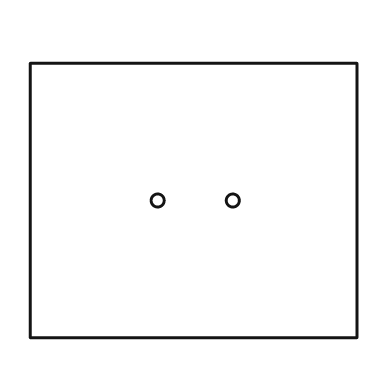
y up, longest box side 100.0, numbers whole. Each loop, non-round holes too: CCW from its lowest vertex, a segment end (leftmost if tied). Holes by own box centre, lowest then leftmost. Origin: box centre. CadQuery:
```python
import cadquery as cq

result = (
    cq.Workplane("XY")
    .moveTo(-50.0, -42.0)
    .lineTo(50.0, -42.0)
    .lineTo(50.0, 42.0)
    .lineTo(-50.0, 42.0)
    .close()
    .moveTo(-11.0, 0.0)
    .circle(2.0)
    .moveTo(12.0, 0.0)
    .circle(2.0)
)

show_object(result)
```